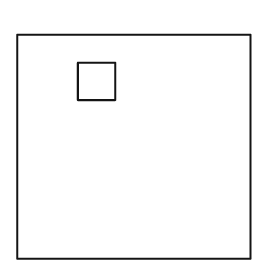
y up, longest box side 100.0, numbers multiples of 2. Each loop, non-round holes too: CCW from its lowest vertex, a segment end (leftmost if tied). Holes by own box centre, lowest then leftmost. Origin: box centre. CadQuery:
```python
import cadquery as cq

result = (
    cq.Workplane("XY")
    .moveTo(-50.0, -48.0)
    .lineTo(50.0, -48.0)
    .lineTo(50.0, 48.0)
    .lineTo(-50.0, 48.0)
    .close()
    .moveTo(-24.0, 20.0)
    .lineTo(-8.0, 20.0)
    .lineTo(-8.0, 36.0)
    .lineTo(-24.0, 36.0)
    .close()
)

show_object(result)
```